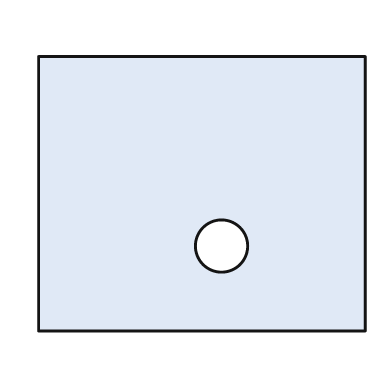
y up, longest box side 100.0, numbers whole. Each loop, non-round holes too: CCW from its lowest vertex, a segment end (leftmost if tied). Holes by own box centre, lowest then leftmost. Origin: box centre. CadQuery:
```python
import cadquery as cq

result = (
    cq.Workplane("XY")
    .moveTo(-50.0, -42.0)
    .lineTo(50.0, -42.0)
    .lineTo(50.0, 42.0)
    .lineTo(-50.0, 42.0)
    .close()
    .moveTo(6.0, -16.0)
    .circle(8.0)
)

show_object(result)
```